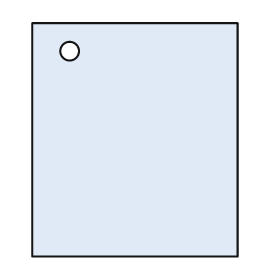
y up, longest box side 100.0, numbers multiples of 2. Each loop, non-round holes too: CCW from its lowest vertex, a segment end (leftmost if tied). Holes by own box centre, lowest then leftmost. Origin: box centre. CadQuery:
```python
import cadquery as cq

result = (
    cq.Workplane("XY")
    .moveTo(-44.0, -50.0)
    .lineTo(44.0, -50.0)
    .lineTo(44.0, 50.0)
    .lineTo(-44.0, 50.0)
    .close()
    .moveTo(-28.0, 38.0)
    .circle(4.0)
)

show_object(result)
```